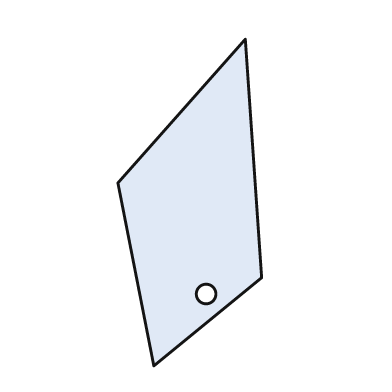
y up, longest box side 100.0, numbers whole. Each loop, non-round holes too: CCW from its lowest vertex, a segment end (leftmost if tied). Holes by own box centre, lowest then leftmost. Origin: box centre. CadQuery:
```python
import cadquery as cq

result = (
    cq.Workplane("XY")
    .moveTo(-11.0, -50.0)
    .lineTo(22.0, -23.0)
    .lineTo(17.0, 50.0)
    .lineTo(-22.0, 6.0)
    .close()
    .moveTo(5.0, -28.0)
    .circle(3.0)
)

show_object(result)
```